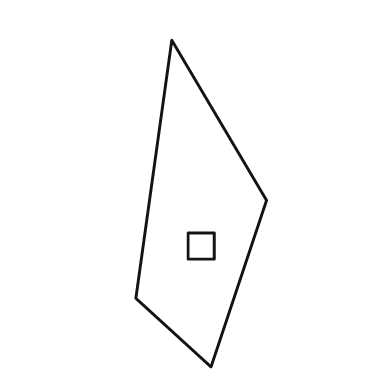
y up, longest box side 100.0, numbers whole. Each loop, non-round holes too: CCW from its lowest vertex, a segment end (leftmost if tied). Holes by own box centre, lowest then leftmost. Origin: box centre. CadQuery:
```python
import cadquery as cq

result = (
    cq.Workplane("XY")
    .moveTo(3.0, -50.0)
    .lineTo(20.0, 1.0)
    .lineTo(-9.0, 50.0)
    .lineTo(-20.0, -29.0)
    .close()
    .moveTo(-4.0, -17.0)
    .lineTo(4.0, -17.0)
    .lineTo(4.0, -9.0)
    .lineTo(-4.0, -9.0)
    .close()
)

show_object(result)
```